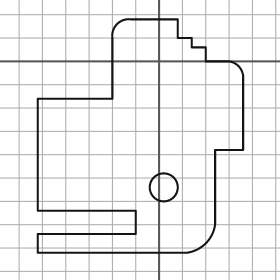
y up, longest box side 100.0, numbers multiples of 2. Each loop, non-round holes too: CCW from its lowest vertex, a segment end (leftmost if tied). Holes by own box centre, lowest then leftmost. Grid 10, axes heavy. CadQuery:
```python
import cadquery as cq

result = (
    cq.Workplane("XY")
    .moveTo(-52.0, -82.0)
    .lineTo(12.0, -82.0)
    .threePointArc((20.0, -78.0), (24.0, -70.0))
    .lineTo(24.0, -38.0)
    .lineTo(36.0, -38.0)
    .lineTo(36.0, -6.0)
    .threePointArc((34.0, -2.0), (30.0, 0.0))
    .lineTo(20.0, 0.0)
    .lineTo(20.0, 6.0)
    .lineTo(14.0, 6.0)
    .lineTo(14.0, 10.0)
    .lineTo(8.0, 10.0)
    .lineTo(8.0, 18.0)
    .lineTo(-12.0, 18.0)
    .threePointArc((-18.0, 16.0), (-20.0, 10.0))
    .lineTo(-20.0, -16.0)
    .lineTo(-52.0, -16.0)
    .lineTo(-52.0, -64.0)
    .lineTo(-10.0, -64.0)
    .lineTo(-10.0, -74.0)
    .lineTo(-52.0, -74.0)
    .close()
    .moveTo(2.0, -54.0)
    .circle(6.0)
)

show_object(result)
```